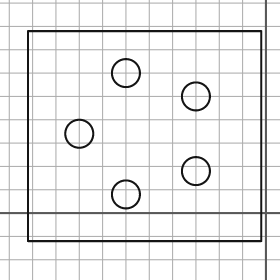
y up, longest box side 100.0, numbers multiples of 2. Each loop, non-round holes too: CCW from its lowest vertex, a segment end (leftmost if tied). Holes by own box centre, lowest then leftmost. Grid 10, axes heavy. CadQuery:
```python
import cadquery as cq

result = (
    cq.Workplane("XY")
    .moveTo(-102.0, -12.0)
    .lineTo(-2.0, -12.0)
    .lineTo(-2.0, 78.0)
    .lineTo(-102.0, 78.0)
    .close()
    .moveTo(-60.0, 8.0)
    .circle(6.0)
    .moveTo(-30.0, 18.0)
    .circle(6.0)
    .moveTo(-80.0, 34.0)
    .circle(6.0)
    .moveTo(-30.0, 50.0)
    .circle(6.0)
    .moveTo(-60.0, 60.0)
    .circle(6.0)
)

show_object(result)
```